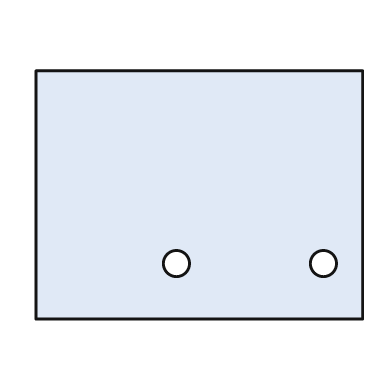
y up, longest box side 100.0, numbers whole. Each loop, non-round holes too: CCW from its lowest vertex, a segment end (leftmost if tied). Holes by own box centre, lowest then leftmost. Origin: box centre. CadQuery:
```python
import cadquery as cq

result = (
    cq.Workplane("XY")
    .moveTo(-50.0, -38.0)
    .lineTo(50.0, -38.0)
    .lineTo(50.0, 38.0)
    .lineTo(-50.0, 38.0)
    .close()
    .moveTo(-7.0, -21.0)
    .circle(4.0)
    .moveTo(38.0, -21.0)
    .circle(4.0)
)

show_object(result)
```